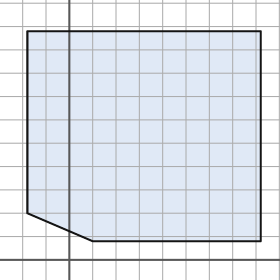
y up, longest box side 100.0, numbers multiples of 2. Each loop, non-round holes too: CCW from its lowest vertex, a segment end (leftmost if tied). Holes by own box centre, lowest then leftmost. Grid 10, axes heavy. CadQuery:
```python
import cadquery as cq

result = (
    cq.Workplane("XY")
    .moveTo(10.0, 8.0)
    .lineTo(82.0, 8.0)
    .lineTo(82.0, 98.0)
    .lineTo(-18.0, 98.0)
    .lineTo(-18.0, 20.0)
    .close()
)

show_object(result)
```